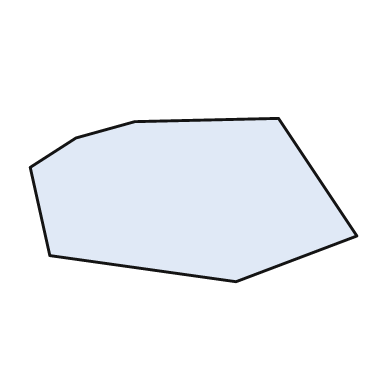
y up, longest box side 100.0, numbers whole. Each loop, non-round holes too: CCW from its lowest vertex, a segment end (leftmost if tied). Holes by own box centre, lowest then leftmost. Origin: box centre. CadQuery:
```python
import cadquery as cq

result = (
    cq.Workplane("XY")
    .moveTo(13.0, -25.0)
    .lineTo(50.0, -11.0)
    .lineTo(26.0, 25.0)
    .lineTo(-18.0, 24.0)
    .lineTo(-36.0, 19.0)
    .lineTo(-50.0, 10.0)
    .lineTo(-44.0, -17.0)
    .close()
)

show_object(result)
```